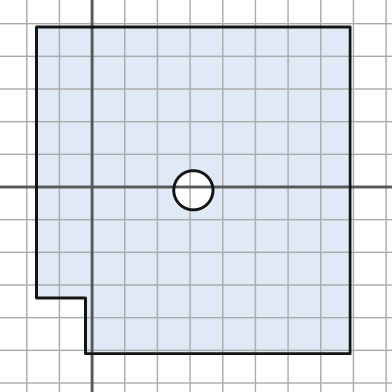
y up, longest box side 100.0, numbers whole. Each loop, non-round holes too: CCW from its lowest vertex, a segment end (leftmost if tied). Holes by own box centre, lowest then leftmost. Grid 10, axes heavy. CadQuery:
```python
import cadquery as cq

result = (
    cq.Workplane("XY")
    .moveTo(-2.0, -51.0)
    .lineTo(79.0, -51.0)
    .lineTo(79.0, 49.0)
    .lineTo(-17.0, 49.0)
    .lineTo(-17.0, -34.0)
    .lineTo(-2.0, -34.0)
    .close()
    .moveTo(31.0, -1.0)
    .circle(6.0)
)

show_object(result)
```